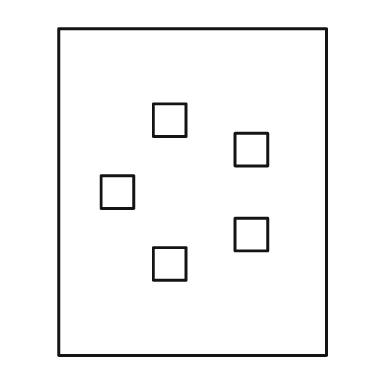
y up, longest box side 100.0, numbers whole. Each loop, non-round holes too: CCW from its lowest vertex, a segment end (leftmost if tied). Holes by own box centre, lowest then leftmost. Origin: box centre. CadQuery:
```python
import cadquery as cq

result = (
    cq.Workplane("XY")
    .moveTo(-41.0, -50.0)
    .lineTo(41.0, -50.0)
    .lineTo(41.0, 50.0)
    .lineTo(-41.0, 50.0)
    .close()
    .moveTo(-12.0, -27.0)
    .lineTo(-2.0, -27.0)
    .lineTo(-2.0, -17.0)
    .lineTo(-12.0, -17.0)
    .close()
    .moveTo(13.0, -18.0)
    .lineTo(23.0, -18.0)
    .lineTo(23.0, -8.0)
    .lineTo(13.0, -8.0)
    .close()
    .moveTo(-28.0, -5.0)
    .lineTo(-18.0, -5.0)
    .lineTo(-18.0, 5.0)
    .lineTo(-28.0, 5.0)
    .close()
    .moveTo(13.0, 8.0)
    .lineTo(23.0, 8.0)
    .lineTo(23.0, 18.0)
    .lineTo(13.0, 18.0)
    .close()
    .moveTo(-12.0, 17.0)
    .lineTo(-2.0, 17.0)
    .lineTo(-2.0, 27.0)
    .lineTo(-12.0, 27.0)
    .close()
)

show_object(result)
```